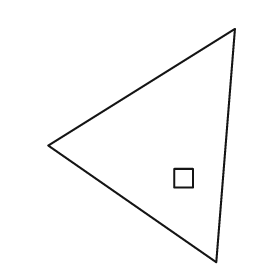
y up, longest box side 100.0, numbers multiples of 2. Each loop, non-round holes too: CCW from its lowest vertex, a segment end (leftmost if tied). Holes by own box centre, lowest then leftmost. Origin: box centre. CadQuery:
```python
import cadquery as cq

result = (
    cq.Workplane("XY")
    .moveTo(32.0, -50.0)
    .lineTo(40.0, 50.0)
    .lineTo(-40.0, 0.0)
    .close()
    .moveTo(14.0, -18.0)
    .lineTo(22.0, -18.0)
    .lineTo(22.0, -10.0)
    .lineTo(14.0, -10.0)
    .close()
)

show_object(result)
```